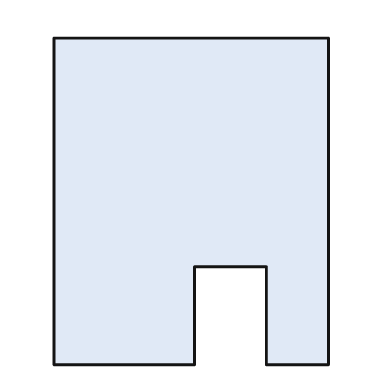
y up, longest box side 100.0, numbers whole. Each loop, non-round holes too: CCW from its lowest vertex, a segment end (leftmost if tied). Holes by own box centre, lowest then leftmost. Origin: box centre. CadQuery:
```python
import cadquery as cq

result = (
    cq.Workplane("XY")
    .moveTo(-42.0, -50.0)
    .lineTo(1.0, -50.0)
    .lineTo(1.0, -20.0)
    .lineTo(23.0, -20.0)
    .lineTo(23.0, -50.0)
    .lineTo(42.0, -50.0)
    .lineTo(42.0, 50.0)
    .lineTo(-42.0, 50.0)
    .close()
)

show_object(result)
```